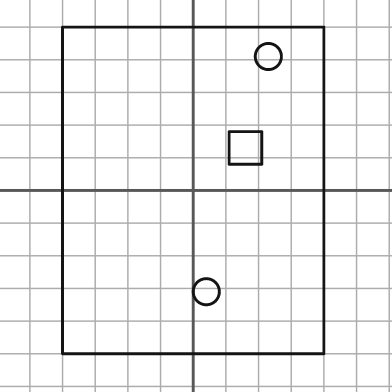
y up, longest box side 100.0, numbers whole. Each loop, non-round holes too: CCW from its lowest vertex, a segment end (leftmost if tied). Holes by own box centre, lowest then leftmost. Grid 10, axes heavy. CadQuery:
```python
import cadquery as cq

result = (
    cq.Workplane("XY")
    .moveTo(-40.0, -50.0)
    .lineTo(40.0, -50.0)
    .lineTo(40.0, 50.0)
    .lineTo(-40.0, 50.0)
    .close()
    .moveTo(4.0, -31.0)
    .circle(4.0)
    .moveTo(11.0, 8.0)
    .lineTo(21.0, 8.0)
    .lineTo(21.0, 18.0)
    .lineTo(11.0, 18.0)
    .close()
    .moveTo(23.0, 41.0)
    .circle(4.0)
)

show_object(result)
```